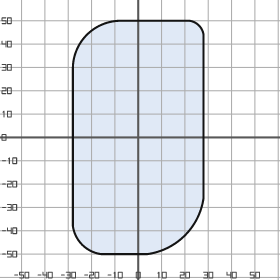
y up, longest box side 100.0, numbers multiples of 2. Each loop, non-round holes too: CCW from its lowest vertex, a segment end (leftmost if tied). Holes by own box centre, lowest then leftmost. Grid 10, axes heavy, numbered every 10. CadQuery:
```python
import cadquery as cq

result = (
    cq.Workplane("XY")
    .moveTo(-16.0, -50.0)
    .lineTo(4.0, -50.0)
    .threePointArc((20.0, -42.0), (28.0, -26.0))
    .lineTo(28.0, 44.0)
    .threePointArc((26.0, 48.0), (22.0, 50.0))
    .lineTo(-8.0, 50.0)
    .threePointArc((-22.0, 44.0), (-28.0, 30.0))
    .lineTo(-28.0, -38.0)
    .threePointArc((-24.0, -46.0), (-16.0, -50.0))
    .close()
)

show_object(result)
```